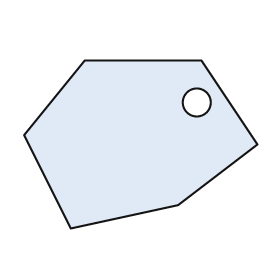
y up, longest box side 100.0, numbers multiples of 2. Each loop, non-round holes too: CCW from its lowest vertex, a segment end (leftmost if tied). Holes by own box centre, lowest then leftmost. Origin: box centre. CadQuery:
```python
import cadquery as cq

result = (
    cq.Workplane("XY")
    .moveTo(-30.0, -36.0)
    .lineTo(16.0, -26.0)
    .lineTo(50.0, 0.0)
    .lineTo(26.0, 36.0)
    .lineTo(-24.0, 36.0)
    .lineTo(-50.0, 4.0)
    .close()
    .moveTo(24.0, 18.0)
    .circle(6.0)
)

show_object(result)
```